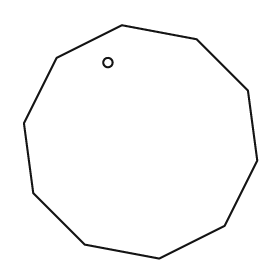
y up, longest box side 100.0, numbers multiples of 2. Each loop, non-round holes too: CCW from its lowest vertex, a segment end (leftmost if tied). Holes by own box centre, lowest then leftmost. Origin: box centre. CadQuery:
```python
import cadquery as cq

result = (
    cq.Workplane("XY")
    .moveTo(8.0, -50.0)
    .lineTo(36.0, -36.0)
    .lineTo(50.0, -8.0)
    .lineTo(46.0, 22.0)
    .lineTo(24.0, 44.0)
    .lineTo(-8.0, 50.0)
    .lineTo(-36.0, 36.0)
    .lineTo(-50.0, 8.0)
    .lineTo(-46.0, -22.0)
    .lineTo(-24.0, -44.0)
    .close()
    .moveTo(-14.0, 34.0)
    .circle(2.0)
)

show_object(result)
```